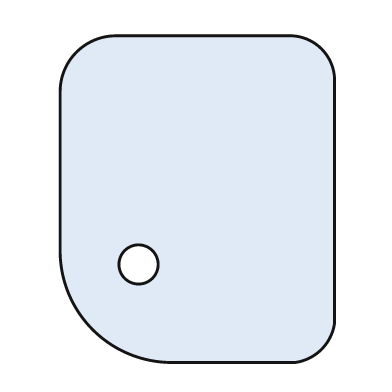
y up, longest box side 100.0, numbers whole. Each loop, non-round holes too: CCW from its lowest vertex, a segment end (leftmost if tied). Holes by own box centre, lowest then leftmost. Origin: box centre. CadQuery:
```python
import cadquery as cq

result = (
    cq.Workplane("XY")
    .moveTo(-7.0, -50.0)
    .lineTo(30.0, -50.0)
    .threePointArc((38.0, -46.0), (42.0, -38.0))
    .lineTo(42.0, 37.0)
    .threePointArc((38.0, 46.0), (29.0, 50.0))
    .lineTo(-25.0, 50.0)
    .threePointArc((-37.0, 45.0), (-42.0, 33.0))
    .lineTo(-42.0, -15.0)
    .threePointArc((-32.0, -40.0), (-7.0, -50.0))
    .close()
    .moveTo(-18.0, -20.0)
    .circle(6.0)
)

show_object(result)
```